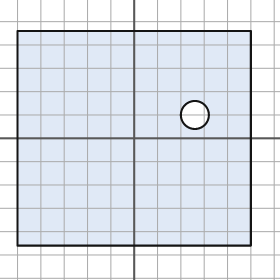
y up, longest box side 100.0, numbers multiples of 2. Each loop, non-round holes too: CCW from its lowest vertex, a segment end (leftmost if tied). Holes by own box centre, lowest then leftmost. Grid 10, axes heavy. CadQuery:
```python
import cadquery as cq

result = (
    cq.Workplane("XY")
    .moveTo(-50.0, -46.0)
    .lineTo(50.0, -46.0)
    .lineTo(50.0, 46.0)
    .lineTo(-50.0, 46.0)
    .close()
    .moveTo(26.0, 10.0)
    .circle(6.0)
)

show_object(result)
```